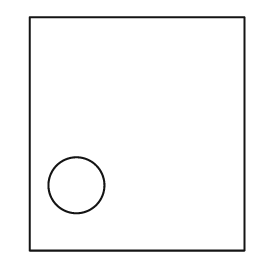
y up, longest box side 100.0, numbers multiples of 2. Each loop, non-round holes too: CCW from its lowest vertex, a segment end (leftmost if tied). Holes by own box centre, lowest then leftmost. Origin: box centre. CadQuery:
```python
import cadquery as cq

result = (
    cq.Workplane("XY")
    .moveTo(-46.0, -50.0)
    .lineTo(46.0, -50.0)
    .lineTo(46.0, 50.0)
    .lineTo(-46.0, 50.0)
    .close()
    .moveTo(-26.0, -22.0)
    .circle(12.0)
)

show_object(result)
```